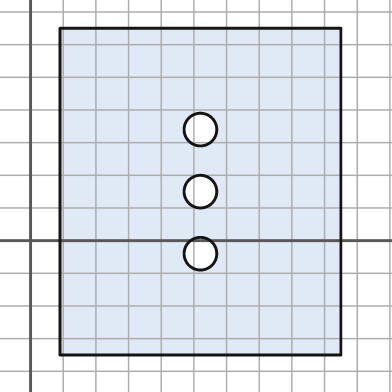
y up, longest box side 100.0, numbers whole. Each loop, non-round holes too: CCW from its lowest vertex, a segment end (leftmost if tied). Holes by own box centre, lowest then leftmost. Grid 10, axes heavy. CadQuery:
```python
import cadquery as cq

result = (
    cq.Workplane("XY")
    .moveTo(9.0, -35.0)
    .lineTo(95.0, -35.0)
    .lineTo(95.0, 65.0)
    .lineTo(9.0, 65.0)
    .close()
    .moveTo(52.0, -4.0)
    .circle(5.0)
    .moveTo(52.0, 15.0)
    .circle(5.0)
    .moveTo(52.0, 34.0)
    .circle(5.0)
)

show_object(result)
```